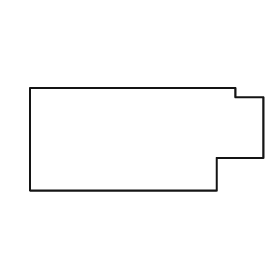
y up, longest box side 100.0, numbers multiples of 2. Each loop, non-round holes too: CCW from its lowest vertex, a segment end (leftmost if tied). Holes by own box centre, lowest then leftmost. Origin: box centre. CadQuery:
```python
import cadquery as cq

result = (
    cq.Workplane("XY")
    .moveTo(-50.0, -22.0)
    .lineTo(30.0, -22.0)
    .lineTo(30.0, -8.0)
    .lineTo(50.0, -8.0)
    .lineTo(50.0, 18.0)
    .lineTo(38.0, 18.0)
    .lineTo(38.0, 22.0)
    .lineTo(-50.0, 22.0)
    .close()
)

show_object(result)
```